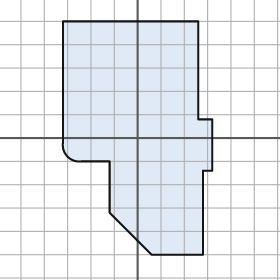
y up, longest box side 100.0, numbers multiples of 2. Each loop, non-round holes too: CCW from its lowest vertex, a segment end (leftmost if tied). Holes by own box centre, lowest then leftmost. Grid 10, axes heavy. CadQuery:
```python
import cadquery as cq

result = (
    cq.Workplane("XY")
    .moveTo(6.0, -50.0)
    .lineTo(28.0, -50.0)
    .lineTo(28.0, -14.0)
    .lineTo(32.0, -14.0)
    .lineTo(32.0, 8.0)
    .lineTo(26.0, 8.0)
    .lineTo(26.0, 50.0)
    .lineTo(-32.0, 50.0)
    .lineTo(-32.0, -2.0)
    .threePointArc((-30.0, -8.0), (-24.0, -10.0))
    .lineTo(-12.0, -10.0)
    .lineTo(-12.0, -32.0)
    .close()
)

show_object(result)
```